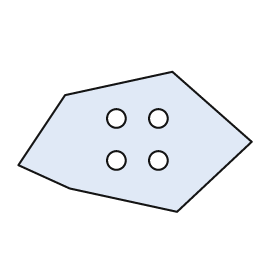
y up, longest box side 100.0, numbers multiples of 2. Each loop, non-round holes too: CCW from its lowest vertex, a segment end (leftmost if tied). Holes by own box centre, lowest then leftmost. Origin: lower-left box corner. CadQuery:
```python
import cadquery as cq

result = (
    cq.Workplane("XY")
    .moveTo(68.0, 0.0)
    .lineTo(100.0, 30.0)
    .lineTo(66.0, 60.0)
    .lineTo(20.0, 50.0)
    .lineTo(0.0, 20.0)
    .lineTo(22.0, 10.0)
    .close()
    .moveTo(42.0, 22.0)
    .circle(4.0)
    .moveTo(60.0, 22.0)
    .circle(4.0)
    .moveTo(42.0, 40.0)
    .circle(4.0)
    .moveTo(60.0, 40.0)
    .circle(4.0)
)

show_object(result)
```